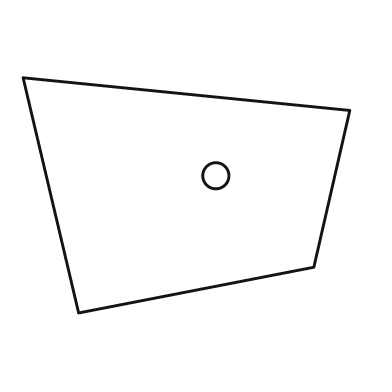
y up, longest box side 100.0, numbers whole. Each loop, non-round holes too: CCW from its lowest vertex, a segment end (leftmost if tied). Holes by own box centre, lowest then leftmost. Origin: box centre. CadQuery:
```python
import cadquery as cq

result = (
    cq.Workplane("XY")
    .moveTo(-33.0, -36.0)
    .lineTo(39.0, -22.0)
    .lineTo(50.0, 26.0)
    .lineTo(-50.0, 36.0)
    .close()
    .moveTo(9.0, 6.0)
    .circle(4.0)
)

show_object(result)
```